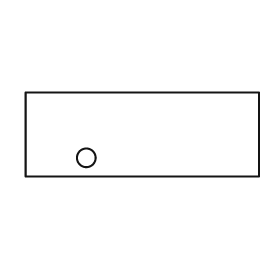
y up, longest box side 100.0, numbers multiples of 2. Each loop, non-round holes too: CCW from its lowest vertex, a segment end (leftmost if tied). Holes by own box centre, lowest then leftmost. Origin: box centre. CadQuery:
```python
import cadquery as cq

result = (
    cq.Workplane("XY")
    .moveTo(-50.0, -18.0)
    .lineTo(50.0, -18.0)
    .lineTo(50.0, 18.0)
    .lineTo(-50.0, 18.0)
    .close()
    .moveTo(-24.0, -10.0)
    .circle(4.0)
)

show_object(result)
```